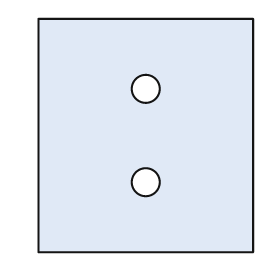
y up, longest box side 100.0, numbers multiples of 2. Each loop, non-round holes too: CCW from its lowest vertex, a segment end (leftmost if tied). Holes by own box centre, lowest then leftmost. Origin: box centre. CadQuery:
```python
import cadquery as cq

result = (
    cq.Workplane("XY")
    .moveTo(-46.0, -50.0)
    .lineTo(46.0, -50.0)
    .lineTo(46.0, 50.0)
    .lineTo(-46.0, 50.0)
    .close()
    .moveTo(0.0, -20.0)
    .circle(6.0)
    .moveTo(0.0, 20.0)
    .circle(6.0)
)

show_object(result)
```